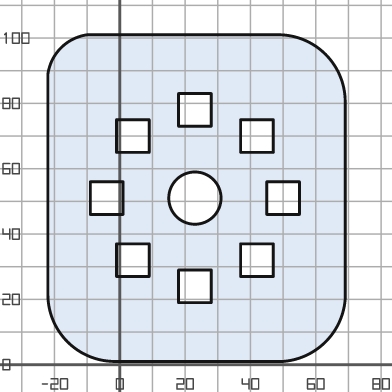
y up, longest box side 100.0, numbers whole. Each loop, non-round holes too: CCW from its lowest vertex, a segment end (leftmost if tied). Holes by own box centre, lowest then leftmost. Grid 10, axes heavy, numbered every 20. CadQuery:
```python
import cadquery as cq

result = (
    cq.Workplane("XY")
    .moveTo(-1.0, 1.0)
    .lineTo(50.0, 1.0)
    .threePointArc((63.0, 7.0), (69.0, 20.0))
    .lineTo(69.0, 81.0)
    .threePointArc((63.0, 95.0), (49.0, 101.0))
    .lineTo(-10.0, 101.0)
    .threePointArc((-18.0, 97.0), (-22.0, 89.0))
    .lineTo(-22.0, 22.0)
    .threePointArc((-16.0, 7.0), (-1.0, 1.0))
    .close()
    .moveTo(18.0, 19.0)
    .lineTo(28.0, 19.0)
    .lineTo(28.0, 29.0)
    .lineTo(18.0, 29.0)
    .close()
    .moveTo(-1.0, 27.0)
    .lineTo(9.0, 27.0)
    .lineTo(9.0, 37.0)
    .lineTo(-1.0, 37.0)
    .close()
    .moveTo(37.0, 27.0)
    .lineTo(47.0, 27.0)
    .lineTo(47.0, 37.0)
    .lineTo(37.0, 37.0)
    .close()
    .moveTo(-9.0, 46.0)
    .lineTo(1.0, 46.0)
    .lineTo(1.0, 56.0)
    .lineTo(-9.0, 56.0)
    .close()
    .moveTo(23.0, 51.0)
    .circle(8.0)
    .moveTo(45.0, 46.0)
    .lineTo(55.0, 46.0)
    .lineTo(55.0, 56.0)
    .lineTo(45.0, 56.0)
    .close()
    .moveTo(-1.0, 65.0)
    .lineTo(9.0, 65.0)
    .lineTo(9.0, 75.0)
    .lineTo(-1.0, 75.0)
    .close()
    .moveTo(37.0, 65.0)
    .lineTo(47.0, 65.0)
    .lineTo(47.0, 75.0)
    .lineTo(37.0, 75.0)
    .close()
    .moveTo(18.0, 73.0)
    .lineTo(28.0, 73.0)
    .lineTo(28.0, 83.0)
    .lineTo(18.0, 83.0)
    .close()
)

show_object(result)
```